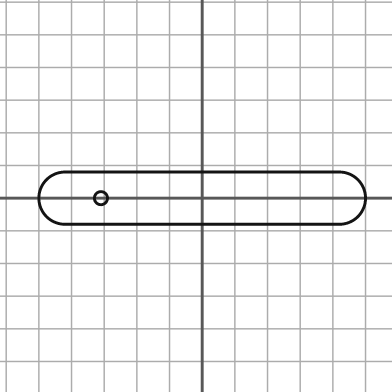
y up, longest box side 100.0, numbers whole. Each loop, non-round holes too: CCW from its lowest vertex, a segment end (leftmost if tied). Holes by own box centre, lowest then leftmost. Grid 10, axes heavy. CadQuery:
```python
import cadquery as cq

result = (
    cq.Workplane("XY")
    .moveTo(-42.0, -8.0)
    .lineTo(42.0, -8.0)
    .threePointArc((50.0, 0.0), (42.0, 8.0))
    .lineTo(-42.0, 8.0)
    .threePointArc((-50.0, 0.0), (-42.0, -8.0))
    .close()
    .moveTo(-31.0, 0.0)
    .circle(2.0)
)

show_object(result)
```